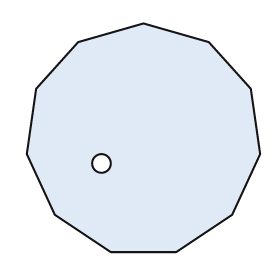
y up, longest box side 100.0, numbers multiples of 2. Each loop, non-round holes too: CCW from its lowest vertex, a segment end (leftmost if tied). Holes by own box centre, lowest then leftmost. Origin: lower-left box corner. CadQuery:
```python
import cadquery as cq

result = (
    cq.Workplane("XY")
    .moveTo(36.0, 0.0)
    .lineTo(64.0, 0.0)
    .lineTo(88.0, 16.0)
    .lineTo(100.0, 42.0)
    .lineTo(96.0, 70.0)
    .lineTo(78.0, 90.0)
    .lineTo(50.0, 98.0)
    .lineTo(22.0, 90.0)
    .lineTo(4.0, 70.0)
    .lineTo(0.0, 42.0)
    .lineTo(12.0, 16.0)
    .close()
    .moveTo(32.0, 38.0)
    .circle(4.0)
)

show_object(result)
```